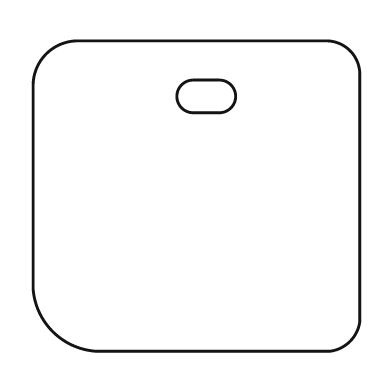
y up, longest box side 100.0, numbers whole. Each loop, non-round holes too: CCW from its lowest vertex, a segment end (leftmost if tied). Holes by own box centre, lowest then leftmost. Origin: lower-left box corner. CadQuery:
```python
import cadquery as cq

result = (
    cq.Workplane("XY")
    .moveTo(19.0, 0.0)
    .lineTo(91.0, 0.0)
    .threePointArc((97.0, 3.0), (100.0, 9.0))
    .lineTo(100.0, 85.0)
    .threePointArc((97.0, 92.0), (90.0, 95.0))
    .lineTo(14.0, 95.0)
    .threePointArc((4.0, 91.0), (0.0, 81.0))
    .lineTo(0.0, 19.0)
    .threePointArc((6.0, 6.0), (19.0, 0.0))
    .close()
    .moveTo(49.0, 73.0)
    .lineTo(57.0, 73.0)
    .threePointArc((62.0, 78.0), (57.0, 83.0))
    .lineTo(49.0, 83.0)
    .threePointArc((44.0, 78.0), (49.0, 73.0))
    .close()
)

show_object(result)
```